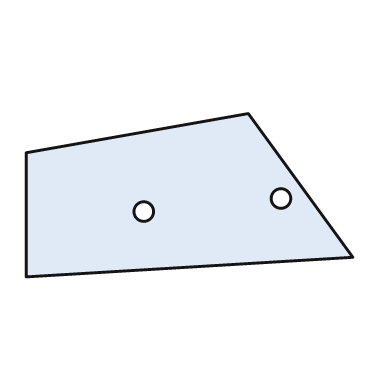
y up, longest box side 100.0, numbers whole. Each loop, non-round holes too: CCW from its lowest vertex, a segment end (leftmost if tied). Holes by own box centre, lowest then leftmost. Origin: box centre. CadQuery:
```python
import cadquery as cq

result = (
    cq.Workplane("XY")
    .moveTo(-50.0, -25.0)
    .lineTo(50.0, -19.0)
    .lineTo(18.0, 25.0)
    .lineTo(-50.0, 13.0)
    .close()
    .moveTo(-14.0, -5.0)
    .circle(3.0)
    .moveTo(28.0, -1.0)
    .circle(3.0)
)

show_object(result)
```